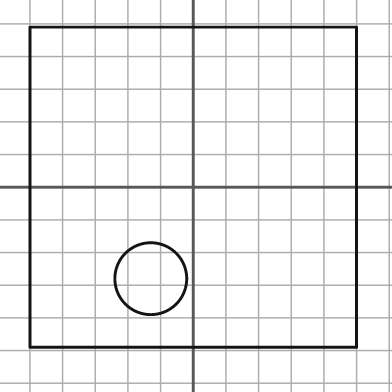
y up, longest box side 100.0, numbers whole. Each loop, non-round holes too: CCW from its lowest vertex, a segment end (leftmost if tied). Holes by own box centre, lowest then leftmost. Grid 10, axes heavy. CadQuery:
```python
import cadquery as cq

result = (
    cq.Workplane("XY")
    .moveTo(-50.0, -49.0)
    .lineTo(50.0, -49.0)
    .lineTo(50.0, 49.0)
    .lineTo(-50.0, 49.0)
    .close()
    .moveTo(-13.0, -28.0)
    .circle(11.0)
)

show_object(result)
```